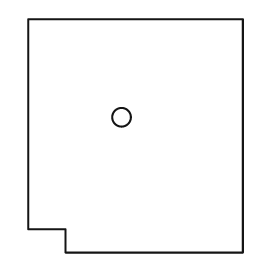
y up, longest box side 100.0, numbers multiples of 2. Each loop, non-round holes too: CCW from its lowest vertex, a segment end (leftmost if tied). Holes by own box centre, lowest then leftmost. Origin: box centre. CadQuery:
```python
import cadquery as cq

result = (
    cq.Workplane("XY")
    .moveTo(-30.0, -50.0)
    .lineTo(46.0, -50.0)
    .lineTo(46.0, 50.0)
    .lineTo(-46.0, 50.0)
    .lineTo(-46.0, -40.0)
    .lineTo(-30.0, -40.0)
    .close()
    .moveTo(-6.0, 8.0)
    .circle(4.0)
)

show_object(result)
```